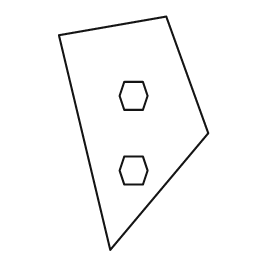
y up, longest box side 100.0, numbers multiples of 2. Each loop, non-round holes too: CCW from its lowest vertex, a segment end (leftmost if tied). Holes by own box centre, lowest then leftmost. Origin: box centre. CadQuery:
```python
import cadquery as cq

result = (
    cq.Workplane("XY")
    .moveTo(-10.0, -50.0)
    .lineTo(32.0, 0.0)
    .lineTo(14.0, 50.0)
    .lineTo(-32.0, 42.0)
    .close()
    .moveTo(-4.0, -22.0)
    .lineTo(4.0, -22.0)
    .lineTo(6.0, -16.0)
    .lineTo(4.0, -10.0)
    .lineTo(-4.0, -10.0)
    .lineTo(-6.0, -16.0)
    .close()
    .moveTo(-4.0, 10.0)
    .lineTo(4.0, 10.0)
    .lineTo(6.0, 16.0)
    .lineTo(4.0, 22.0)
    .lineTo(-4.0, 22.0)
    .lineTo(-6.0, 16.0)
    .close()
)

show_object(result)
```